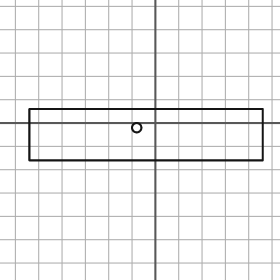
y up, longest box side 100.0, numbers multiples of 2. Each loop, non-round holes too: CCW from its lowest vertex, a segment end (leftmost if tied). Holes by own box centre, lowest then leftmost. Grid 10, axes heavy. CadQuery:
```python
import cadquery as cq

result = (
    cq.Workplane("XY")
    .moveTo(-54.0, -16.0)
    .lineTo(46.0, -16.0)
    .lineTo(46.0, 6.0)
    .lineTo(-54.0, 6.0)
    .close()
    .moveTo(-8.0, -2.0)
    .circle(2.0)
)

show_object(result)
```